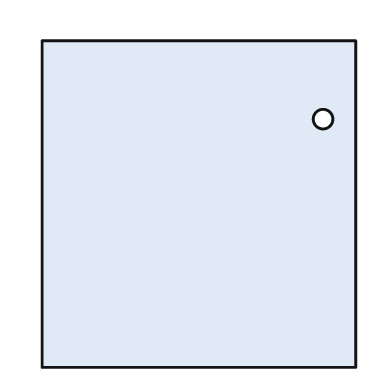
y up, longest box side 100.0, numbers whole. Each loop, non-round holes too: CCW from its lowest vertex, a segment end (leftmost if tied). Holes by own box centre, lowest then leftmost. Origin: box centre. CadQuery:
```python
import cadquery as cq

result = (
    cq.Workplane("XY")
    .moveTo(-48.0, -50.0)
    .lineTo(48.0, -50.0)
    .lineTo(48.0, 50.0)
    .lineTo(-48.0, 50.0)
    .close()
    .moveTo(38.0, 26.0)
    .circle(3.0)
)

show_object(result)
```